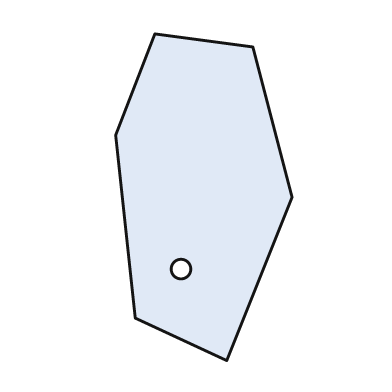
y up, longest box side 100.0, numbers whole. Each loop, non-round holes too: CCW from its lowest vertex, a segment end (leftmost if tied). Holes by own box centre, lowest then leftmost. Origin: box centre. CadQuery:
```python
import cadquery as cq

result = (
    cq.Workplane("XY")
    .moveTo(7.0, -50.0)
    .lineTo(27.0, 0.0)
    .lineTo(15.0, 46.0)
    .lineTo(-15.0, 50.0)
    .lineTo(-27.0, 19.0)
    .lineTo(-21.0, -37.0)
    .close()
    .moveTo(-7.0, -22.0)
    .circle(3.0)
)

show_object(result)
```